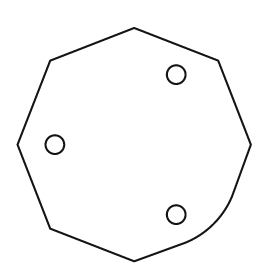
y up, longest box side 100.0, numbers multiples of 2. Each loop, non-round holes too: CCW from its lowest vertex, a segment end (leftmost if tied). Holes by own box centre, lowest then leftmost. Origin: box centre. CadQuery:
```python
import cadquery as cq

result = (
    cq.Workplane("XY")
    .moveTo(0.0, -50.0)
    .lineTo(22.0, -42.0)
    .threePointArc((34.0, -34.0), (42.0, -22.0))
    .lineTo(50.0, 0.0)
    .lineTo(36.0, 36.0)
    .lineTo(0.0, 50.0)
    .lineTo(-36.0, 36.0)
    .lineTo(-50.0, 0.0)
    .lineTo(-36.0, -36.0)
    .close()
    .moveTo(18.0, -30.0)
    .circle(4.0)
    .moveTo(-34.0, 0.0)
    .circle(4.0)
    .moveTo(18.0, 30.0)
    .circle(4.0)
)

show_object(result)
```